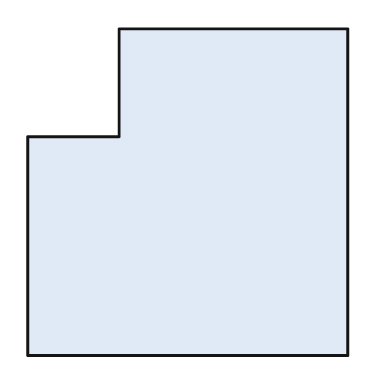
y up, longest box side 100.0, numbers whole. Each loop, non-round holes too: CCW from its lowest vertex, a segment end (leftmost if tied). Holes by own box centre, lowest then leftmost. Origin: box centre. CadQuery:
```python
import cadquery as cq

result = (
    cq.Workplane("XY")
    .moveTo(-49.0, -50.0)
    .lineTo(49.0, -50.0)
    .lineTo(49.0, 50.0)
    .lineTo(-21.0, 50.0)
    .lineTo(-21.0, 17.0)
    .lineTo(-49.0, 17.0)
    .close()
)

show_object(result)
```